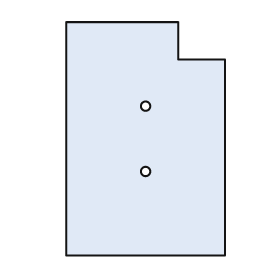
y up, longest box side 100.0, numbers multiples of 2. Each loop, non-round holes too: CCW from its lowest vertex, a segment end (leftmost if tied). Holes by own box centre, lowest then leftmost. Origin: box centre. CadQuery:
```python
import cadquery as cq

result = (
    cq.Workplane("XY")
    .moveTo(-34.0, -50.0)
    .lineTo(34.0, -50.0)
    .lineTo(34.0, 34.0)
    .lineTo(14.0, 34.0)
    .lineTo(14.0, 50.0)
    .lineTo(-34.0, 50.0)
    .close()
    .moveTo(0.0, -14.0)
    .circle(2.0)
    .moveTo(0.0, 14.0)
    .circle(2.0)
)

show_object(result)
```